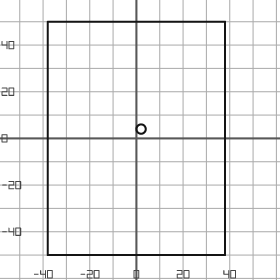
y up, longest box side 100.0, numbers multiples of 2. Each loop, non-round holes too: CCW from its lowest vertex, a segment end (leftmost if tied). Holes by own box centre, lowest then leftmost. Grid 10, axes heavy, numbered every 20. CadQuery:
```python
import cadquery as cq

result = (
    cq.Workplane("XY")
    .moveTo(-38.0, -50.0)
    .lineTo(38.0, -50.0)
    .lineTo(38.0, 50.0)
    .lineTo(-38.0, 50.0)
    .close()
    .moveTo(2.0, 4.0)
    .circle(2.0)
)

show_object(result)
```